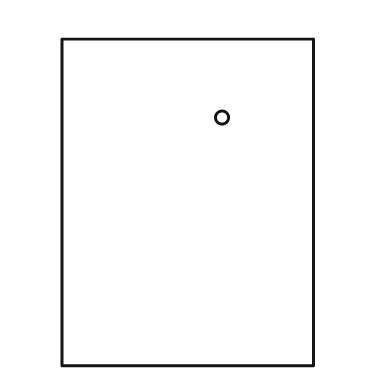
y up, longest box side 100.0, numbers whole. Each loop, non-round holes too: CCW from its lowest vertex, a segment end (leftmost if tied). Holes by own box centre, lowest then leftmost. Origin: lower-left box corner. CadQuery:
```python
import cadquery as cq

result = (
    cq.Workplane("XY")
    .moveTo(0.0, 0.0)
    .lineTo(77.0, 0.0)
    .lineTo(77.0, 100.0)
    .lineTo(0.0, 100.0)
    .close()
    .moveTo(49.0, 76.0)
    .circle(2.0)
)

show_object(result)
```